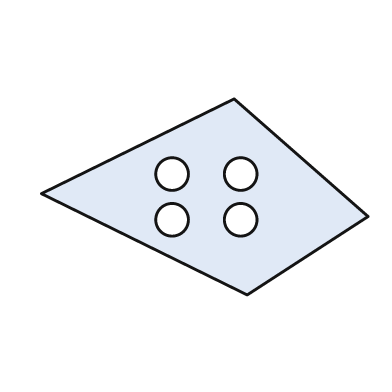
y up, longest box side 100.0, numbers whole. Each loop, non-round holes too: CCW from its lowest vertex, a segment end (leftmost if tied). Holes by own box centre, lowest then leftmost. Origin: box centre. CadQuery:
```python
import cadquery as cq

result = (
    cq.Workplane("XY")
    .moveTo(13.0, -30.0)
    .lineTo(50.0, -6.0)
    .lineTo(9.0, 30.0)
    .lineTo(-50.0, 1.0)
    .close()
    .moveTo(-10.0, -7.0)
    .circle(5.0)
    .moveTo(11.0, -7.0)
    .circle(5.0)
    .moveTo(-10.0, 7.0)
    .circle(5.0)
    .moveTo(11.0, 7.0)
    .circle(5.0)
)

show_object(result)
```